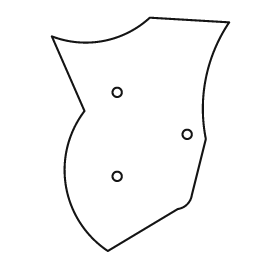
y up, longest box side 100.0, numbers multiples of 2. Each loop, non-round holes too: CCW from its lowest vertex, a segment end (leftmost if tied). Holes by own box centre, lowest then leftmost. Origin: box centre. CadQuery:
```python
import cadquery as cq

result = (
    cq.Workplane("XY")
    .moveTo(-14.0, -50.0)
    .lineTo(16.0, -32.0)
    .threePointArc((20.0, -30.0), (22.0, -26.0))
    .lineTo(28.0, -2.0)
    .threePointArc((28.0, 24.0), (38.0, 48.0))
    .lineTo(4.0, 50.0)
    .threePointArc((-16.0, 40.0), (-38.0, 42.0))
    .lineTo(-24.0, 10.0)
    .threePointArc((-32.0, -22.0), (-14.0, -50.0))
    .close()
    .moveTo(-10.0, -18.0)
    .circle(2.0)
    .moveTo(20.0, 0.0)
    .circle(2.0)
    .moveTo(-10.0, 18.0)
    .circle(2.0)
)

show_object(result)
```